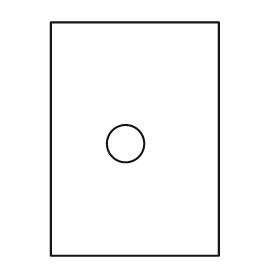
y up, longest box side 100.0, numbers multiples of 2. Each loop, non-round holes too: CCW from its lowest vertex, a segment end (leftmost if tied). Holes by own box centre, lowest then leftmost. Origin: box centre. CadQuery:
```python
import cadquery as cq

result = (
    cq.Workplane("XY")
    .moveTo(-36.0, -50.0)
    .lineTo(36.0, -50.0)
    .lineTo(36.0, 50.0)
    .lineTo(-36.0, 50.0)
    .close()
    .moveTo(-4.0, -2.0)
    .circle(8.0)
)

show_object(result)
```